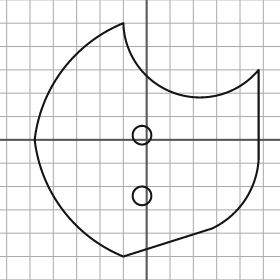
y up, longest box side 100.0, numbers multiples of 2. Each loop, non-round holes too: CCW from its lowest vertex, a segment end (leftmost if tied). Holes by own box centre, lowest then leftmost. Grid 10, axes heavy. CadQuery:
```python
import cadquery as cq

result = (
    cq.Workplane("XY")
    .moveTo(-10.0, -50.0)
    .lineTo(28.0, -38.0)
    .threePointArc((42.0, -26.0), (48.0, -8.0))
    .lineTo(48.0, 30.0)
    .threePointArc((12.0, 20.0), (-10.0, 50.0))
    .threePointArc((-36.0, 30.0), (-48.0, 0.0))
    .threePointArc((-36.0, -30.0), (-10.0, -50.0))
    .close()
    .moveTo(-2.0, -24.0)
    .circle(4.0)
    .moveTo(-2.0, 2.0)
    .circle(4.0)
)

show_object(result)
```